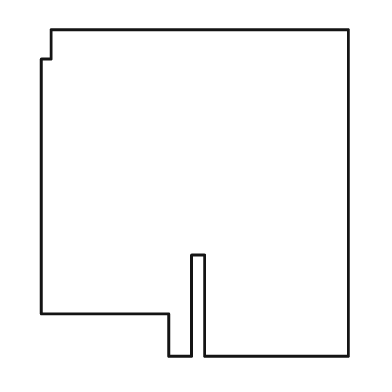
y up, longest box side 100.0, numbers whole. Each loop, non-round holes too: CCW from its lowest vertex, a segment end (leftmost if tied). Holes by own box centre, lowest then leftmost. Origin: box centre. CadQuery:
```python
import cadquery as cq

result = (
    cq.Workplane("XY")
    .moveTo(-8.0, -50.0)
    .lineTo(-1.0, -50.0)
    .lineTo(-1.0, -19.0)
    .lineTo(3.0, -19.0)
    .lineTo(3.0, -50.0)
    .lineTo(47.0, -50.0)
    .lineTo(47.0, 50.0)
    .lineTo(-44.0, 50.0)
    .lineTo(-44.0, 41.0)
    .lineTo(-47.0, 41.0)
    .lineTo(-47.0, -37.0)
    .lineTo(-8.0, -37.0)
    .close()
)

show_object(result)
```